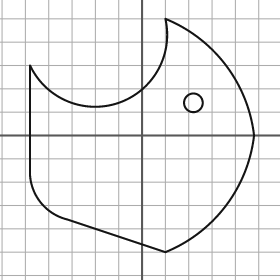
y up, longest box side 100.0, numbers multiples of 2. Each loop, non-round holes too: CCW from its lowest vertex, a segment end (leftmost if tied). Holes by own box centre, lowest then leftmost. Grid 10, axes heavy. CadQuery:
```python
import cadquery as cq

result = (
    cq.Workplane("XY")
    .moveTo(10.0, -50.0)
    .threePointArc((36.0, -30.0), (48.0, 0.0))
    .threePointArc((36.0, 30.0), (10.0, 50.0))
    .threePointArc((-10.0, 14.0), (-48.0, 30.0))
    .lineTo(-48.0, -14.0)
    .threePointArc((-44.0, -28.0), (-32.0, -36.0))
    .close()
    .moveTo(22.0, 14.0)
    .circle(4.0)
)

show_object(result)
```